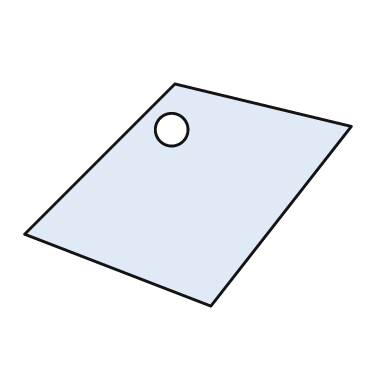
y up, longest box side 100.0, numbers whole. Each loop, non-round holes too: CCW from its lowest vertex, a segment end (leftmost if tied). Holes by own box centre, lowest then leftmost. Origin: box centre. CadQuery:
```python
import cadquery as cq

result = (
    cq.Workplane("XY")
    .moveTo(7.0, -34.0)
    .lineTo(50.0, 21.0)
    .lineTo(-4.0, 34.0)
    .lineTo(-50.0, -12.0)
    .close()
    .moveTo(-5.0, 20.0)
    .circle(5.0)
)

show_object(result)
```